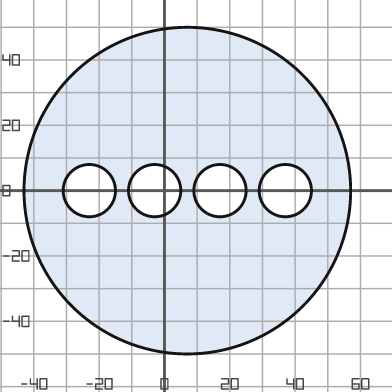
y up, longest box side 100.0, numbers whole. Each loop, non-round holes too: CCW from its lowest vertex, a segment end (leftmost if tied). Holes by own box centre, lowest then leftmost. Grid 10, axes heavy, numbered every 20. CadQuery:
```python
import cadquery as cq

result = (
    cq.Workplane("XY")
    .moveTo(7.0, 0.0)
    .circle(50.0)
    .moveTo(-23.0, 0.0)
    .circle(8.0)
    .moveTo(-3.0, 0.0)
    .circle(8.0)
    .moveTo(17.0, 0.0)
    .circle(8.0)
    .moveTo(37.0, 0.0)
    .circle(8.0)
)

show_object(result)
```